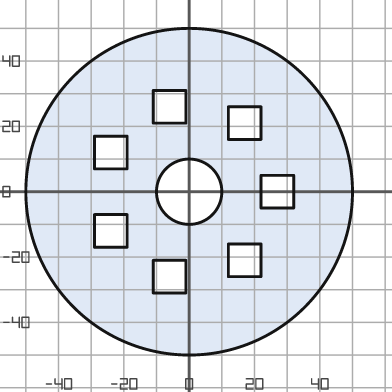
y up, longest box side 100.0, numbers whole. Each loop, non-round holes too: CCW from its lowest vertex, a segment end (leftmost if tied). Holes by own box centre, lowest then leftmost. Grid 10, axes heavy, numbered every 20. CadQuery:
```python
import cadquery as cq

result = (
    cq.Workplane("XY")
    .moveTo(0.0, 0.0)
    .circle(50.0)
    .moveTo(-11.0, -31.0)
    .lineTo(-1.0, -31.0)
    .lineTo(-1.0, -21.0)
    .lineTo(-11.0, -21.0)
    .close()
    .moveTo(12.0, -26.0)
    .lineTo(22.0, -26.0)
    .lineTo(22.0, -16.0)
    .lineTo(12.0, -16.0)
    .close()
    .moveTo(-29.0, -17.0)
    .lineTo(-19.0, -17.0)
    .lineTo(-19.0, -7.0)
    .lineTo(-29.0, -7.0)
    .close()
    .moveTo(0.0, 0.0)
    .circle(10.0)
    .moveTo(22.0, -5.0)
    .lineTo(32.0, -5.0)
    .lineTo(32.0, 5.0)
    .lineTo(22.0, 5.0)
    .close()
    .moveTo(-29.0, 7.0)
    .lineTo(-19.0, 7.0)
    .lineTo(-19.0, 17.0)
    .lineTo(-29.0, 17.0)
    .close()
    .moveTo(12.0, 16.0)
    .lineTo(22.0, 16.0)
    .lineTo(22.0, 26.0)
    .lineTo(12.0, 26.0)
    .close()
    .moveTo(-11.0, 21.0)
    .lineTo(-1.0, 21.0)
    .lineTo(-1.0, 31.0)
    .lineTo(-11.0, 31.0)
    .close()
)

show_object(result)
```